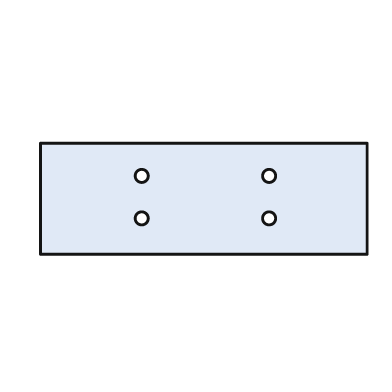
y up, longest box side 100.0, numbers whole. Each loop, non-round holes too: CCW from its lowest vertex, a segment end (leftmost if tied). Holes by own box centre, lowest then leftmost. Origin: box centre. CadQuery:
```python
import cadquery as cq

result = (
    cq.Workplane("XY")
    .moveTo(-50.0, -17.0)
    .lineTo(50.0, -17.0)
    .lineTo(50.0, 17.0)
    .lineTo(-50.0, 17.0)
    .close()
    .moveTo(-19.0, -6.0)
    .circle(2.0)
    .moveTo(20.0, -6.0)
    .circle(2.0)
    .moveTo(-19.0, 7.0)
    .circle(2.0)
    .moveTo(20.0, 7.0)
    .circle(2.0)
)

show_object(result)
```